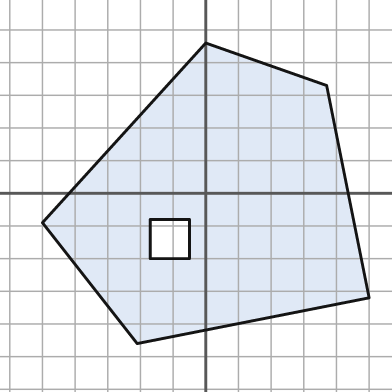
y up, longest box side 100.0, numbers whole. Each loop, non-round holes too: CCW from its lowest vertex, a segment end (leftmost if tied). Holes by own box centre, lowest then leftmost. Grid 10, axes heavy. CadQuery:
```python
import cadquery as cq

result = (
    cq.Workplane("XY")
    .moveTo(-21.0, -46.0)
    .lineTo(50.0, -32.0)
    .lineTo(37.0, 33.0)
    .lineTo(0.0, 46.0)
    .lineTo(-50.0, -9.0)
    .close()
    .moveTo(-17.0, -20.0)
    .lineTo(-5.0, -20.0)
    .lineTo(-5.0, -8.0)
    .lineTo(-17.0, -8.0)
    .close()
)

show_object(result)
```